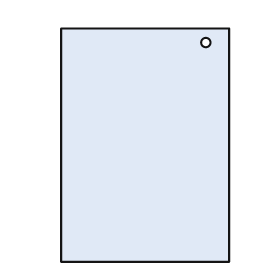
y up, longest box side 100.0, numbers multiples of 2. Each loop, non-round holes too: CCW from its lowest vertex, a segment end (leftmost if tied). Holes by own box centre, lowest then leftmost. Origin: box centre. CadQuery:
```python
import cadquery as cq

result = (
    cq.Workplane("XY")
    .moveTo(-36.0, -50.0)
    .lineTo(36.0, -50.0)
    .lineTo(36.0, 50.0)
    .lineTo(-36.0, 50.0)
    .close()
    .moveTo(26.0, 44.0)
    .circle(2.0)
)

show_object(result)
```